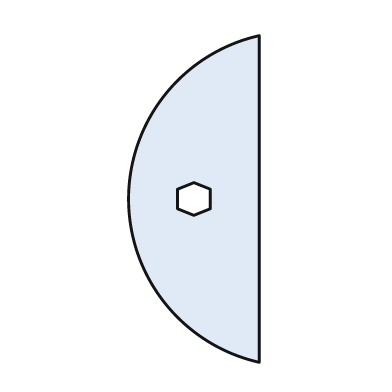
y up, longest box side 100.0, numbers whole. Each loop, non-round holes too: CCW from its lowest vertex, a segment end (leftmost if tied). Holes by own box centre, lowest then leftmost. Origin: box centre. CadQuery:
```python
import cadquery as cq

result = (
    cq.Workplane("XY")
    .moveTo(20.0, -50.0)
    .lineTo(20.0, 50.0)
    .threePointArc((-20.0, 0.0), (20.0, -50.0))
    .close()
    .moveTo(0.0, -5.0)
    .lineTo(5.0, -3.0)
    .lineTo(5.0, 3.0)
    .lineTo(0.0, 5.0)
    .lineTo(-5.0, 3.0)
    .lineTo(-5.0, -3.0)
    .close()
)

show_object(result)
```